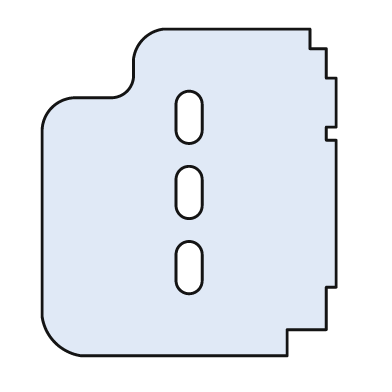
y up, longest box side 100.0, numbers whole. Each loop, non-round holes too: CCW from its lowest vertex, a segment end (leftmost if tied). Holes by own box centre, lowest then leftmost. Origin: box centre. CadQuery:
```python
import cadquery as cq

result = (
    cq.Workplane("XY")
    .moveTo(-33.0, -50.0)
    .lineTo(30.0, -50.0)
    .lineTo(30.0, -42.0)
    .lineTo(42.0, -42.0)
    .lineTo(42.0, -29.0)
    .lineTo(45.0, -29.0)
    .lineTo(45.0, 16.0)
    .lineTo(42.0, 16.0)
    .lineTo(42.0, 20.0)
    .lineTo(45.0, 20.0)
    .lineTo(45.0, 35.0)
    .lineTo(42.0, 35.0)
    .lineTo(42.0, 44.0)
    .lineTo(37.0, 44.0)
    .lineTo(37.0, 50.0)
    .lineTo(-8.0, 50.0)
    .threePointArc((-14.0, 47.0), (-17.0, 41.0))
    .lineTo(-17.0, 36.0)
    .threePointArc((-19.0, 31.0), (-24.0, 29.0))
    .lineTo(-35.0, 29.0)
    .threePointArc((-42.0, 26.0), (-45.0, 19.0))
    .lineTo(-45.0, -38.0)
    .threePointArc((-41.0, -46.0), (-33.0, -50.0))
    .close()
    .moveTo(-4.0, -27.0)
    .threePointArc((0.0, -31.0), (4.0, -27.0))
    .lineTo(4.0, -19.0)
    .threePointArc((0.0, -15.0), (-4.0, -19.0))
    .close()
    .moveTo(-4.0, -4.0)
    .threePointArc((0.0, -8.0), (4.0, -4.0))
    .lineTo(4.0, 4.0)
    .threePointArc((0.0, 8.0), (-4.0, 4.0))
    .close()
    .moveTo(-4.0, 19.0)
    .threePointArc((0.0, 15.0), (4.0, 19.0))
    .lineTo(4.0, 27.0)
    .threePointArc((0.0, 31.0), (-4.0, 27.0))
    .close()
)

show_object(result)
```